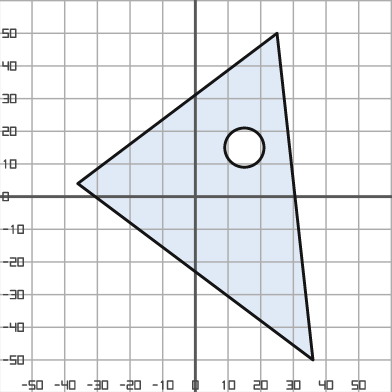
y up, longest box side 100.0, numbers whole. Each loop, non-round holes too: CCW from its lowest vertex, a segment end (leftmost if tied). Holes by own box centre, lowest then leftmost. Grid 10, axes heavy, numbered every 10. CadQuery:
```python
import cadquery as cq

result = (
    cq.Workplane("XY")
    .moveTo(36.0, -50.0)
    .lineTo(25.0, 50.0)
    .lineTo(-36.0, 4.0)
    .close()
    .moveTo(15.0, 15.0)
    .circle(6.0)
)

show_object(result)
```